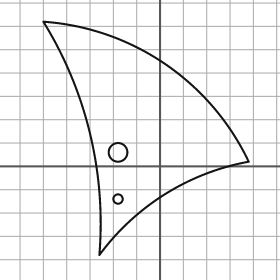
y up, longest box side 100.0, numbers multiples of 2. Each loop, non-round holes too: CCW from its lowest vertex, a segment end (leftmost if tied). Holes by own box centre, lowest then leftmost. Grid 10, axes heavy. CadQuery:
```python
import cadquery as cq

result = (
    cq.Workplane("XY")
    .moveTo(-26.0, -38.0)
    .threePointArc((2.0, -12.0), (38.0, 2.0))
    .threePointArc((2.0, 44.0), (-50.0, 62.0))
    .threePointArc((-30.0, 14.0), (-26.0, -38.0))
    .close()
    .moveTo(-18.0, -14.0)
    .circle(2.0)
    .moveTo(-18.0, 6.0)
    .circle(4.0)
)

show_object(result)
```